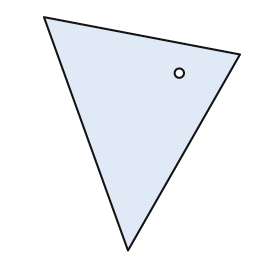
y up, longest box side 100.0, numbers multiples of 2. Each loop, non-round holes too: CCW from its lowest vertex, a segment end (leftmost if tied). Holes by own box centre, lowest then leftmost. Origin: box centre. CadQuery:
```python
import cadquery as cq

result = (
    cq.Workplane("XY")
    .moveTo(-6.0, -50.0)
    .lineTo(42.0, 34.0)
    .lineTo(-42.0, 50.0)
    .close()
    .moveTo(16.0, 26.0)
    .circle(2.0)
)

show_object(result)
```